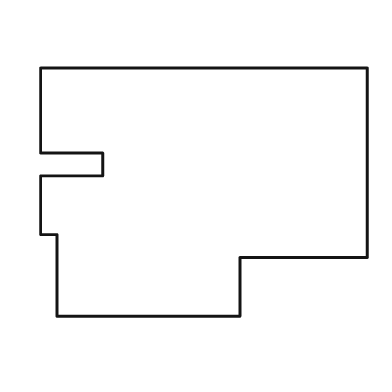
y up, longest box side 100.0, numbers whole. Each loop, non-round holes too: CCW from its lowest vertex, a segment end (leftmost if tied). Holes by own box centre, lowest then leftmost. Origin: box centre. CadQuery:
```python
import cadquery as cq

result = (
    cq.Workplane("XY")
    .moveTo(-45.0, -38.0)
    .lineTo(11.0, -38.0)
    .lineTo(11.0, -20.0)
    .lineTo(50.0, -20.0)
    .lineTo(50.0, 38.0)
    .lineTo(-50.0, 38.0)
    .lineTo(-50.0, 12.0)
    .lineTo(-31.0, 12.0)
    .lineTo(-31.0, 5.0)
    .lineTo(-50.0, 5.0)
    .lineTo(-50.0, -13.0)
    .lineTo(-45.0, -13.0)
    .close()
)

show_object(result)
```